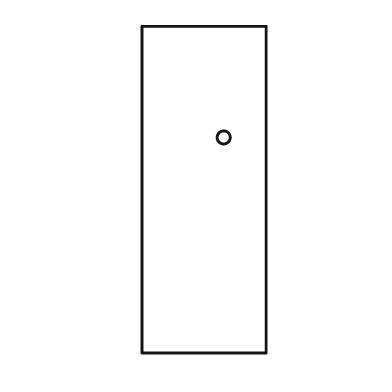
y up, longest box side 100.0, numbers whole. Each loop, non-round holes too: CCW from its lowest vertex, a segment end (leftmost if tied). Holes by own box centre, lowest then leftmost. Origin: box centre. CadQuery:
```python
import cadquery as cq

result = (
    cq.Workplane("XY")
    .moveTo(-19.0, -50.0)
    .lineTo(19.0, -50.0)
    .lineTo(19.0, 50.0)
    .lineTo(-19.0, 50.0)
    .close()
    .moveTo(6.0, 16.0)
    .circle(2.0)
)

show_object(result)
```